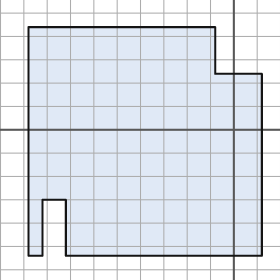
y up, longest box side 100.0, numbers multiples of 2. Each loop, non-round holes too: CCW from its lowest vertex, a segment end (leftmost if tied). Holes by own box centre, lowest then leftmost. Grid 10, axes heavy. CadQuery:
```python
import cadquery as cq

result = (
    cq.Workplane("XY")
    .moveTo(-88.0, -54.0)
    .lineTo(-82.0, -54.0)
    .lineTo(-82.0, -30.0)
    .lineTo(-72.0, -30.0)
    .lineTo(-72.0, -54.0)
    .lineTo(12.0, -54.0)
    .lineTo(12.0, 24.0)
    .lineTo(-8.0, 24.0)
    .lineTo(-8.0, 44.0)
    .lineTo(-88.0, 44.0)
    .close()
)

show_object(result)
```